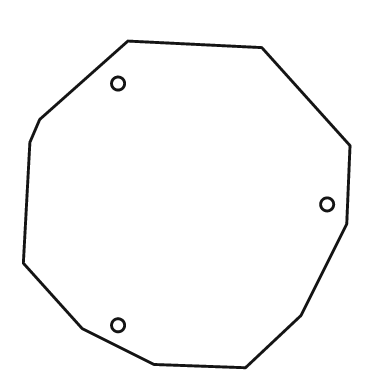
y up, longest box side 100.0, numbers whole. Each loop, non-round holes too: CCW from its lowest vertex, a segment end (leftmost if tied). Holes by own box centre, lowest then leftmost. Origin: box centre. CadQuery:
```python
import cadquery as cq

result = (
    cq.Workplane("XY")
    .moveTo(18.0, -50.0)
    .lineTo(35.0, -34.0)
    .lineTo(49.0, -6.0)
    .lineTo(50.0, 18.0)
    .lineTo(23.0, 48.0)
    .lineTo(-18.0, 50.0)
    .lineTo(-45.0, 26.0)
    .lineTo(-48.0, 19.0)
    .lineTo(-50.0, -18.0)
    .lineTo(-32.0, -38.0)
    .lineTo(-10.0, -49.0)
    .close()
    .moveTo(-21.0, -37.0)
    .circle(2.0)
    .moveTo(43.0, 0.0)
    .circle(2.0)
    .moveTo(-21.0, 37.0)
    .circle(2.0)
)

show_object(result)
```